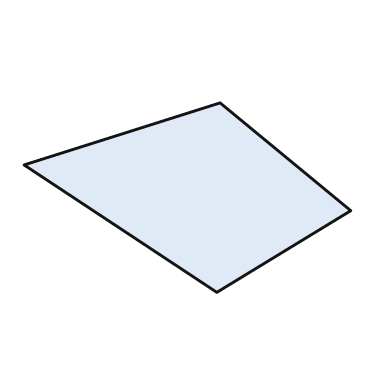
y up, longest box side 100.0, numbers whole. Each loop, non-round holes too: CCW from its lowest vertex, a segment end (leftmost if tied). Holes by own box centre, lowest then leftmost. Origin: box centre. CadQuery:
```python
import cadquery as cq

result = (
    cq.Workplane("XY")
    .moveTo(9.0, -29.0)
    .lineTo(50.0, -4.0)
    .lineTo(10.0, 29.0)
    .lineTo(-50.0, 10.0)
    .close()
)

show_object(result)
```